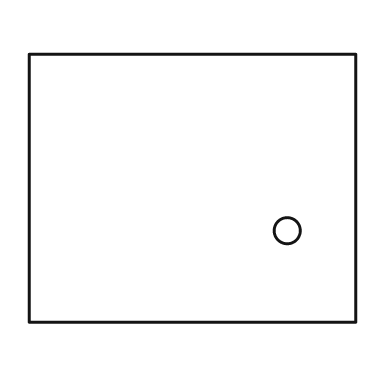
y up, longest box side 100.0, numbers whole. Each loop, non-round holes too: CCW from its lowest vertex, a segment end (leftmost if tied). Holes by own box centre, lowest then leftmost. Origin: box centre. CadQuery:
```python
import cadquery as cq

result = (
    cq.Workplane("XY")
    .moveTo(-50.0, -41.0)
    .lineTo(50.0, -41.0)
    .lineTo(50.0, 41.0)
    .lineTo(-50.0, 41.0)
    .close()
    .moveTo(29.0, -13.0)
    .circle(4.0)
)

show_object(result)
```